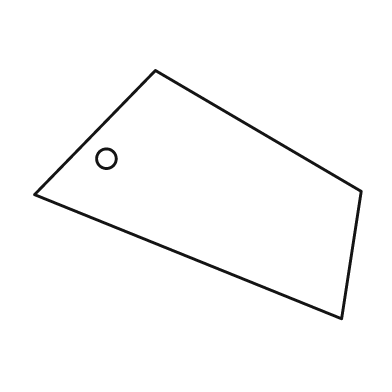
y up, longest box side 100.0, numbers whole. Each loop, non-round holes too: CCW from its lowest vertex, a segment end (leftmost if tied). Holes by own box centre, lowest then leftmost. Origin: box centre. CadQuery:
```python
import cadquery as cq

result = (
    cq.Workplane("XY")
    .moveTo(44.0, -38.0)
    .lineTo(50.0, 1.0)
    .lineTo(-13.0, 38.0)
    .lineTo(-50.0, 0.0)
    .close()
    .moveTo(-28.0, 11.0)
    .circle(3.0)
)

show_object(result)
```